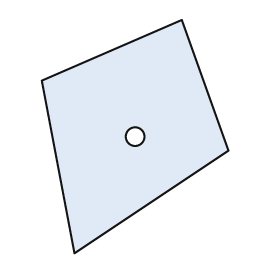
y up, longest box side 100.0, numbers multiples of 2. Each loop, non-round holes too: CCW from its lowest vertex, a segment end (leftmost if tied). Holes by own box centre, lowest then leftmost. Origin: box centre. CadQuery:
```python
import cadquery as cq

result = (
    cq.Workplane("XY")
    .moveTo(-26.0, -50.0)
    .lineTo(40.0, -6.0)
    .lineTo(20.0, 50.0)
    .lineTo(-40.0, 24.0)
    .close()
    .moveTo(0.0, 0.0)
    .circle(4.0)
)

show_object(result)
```